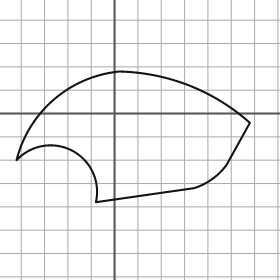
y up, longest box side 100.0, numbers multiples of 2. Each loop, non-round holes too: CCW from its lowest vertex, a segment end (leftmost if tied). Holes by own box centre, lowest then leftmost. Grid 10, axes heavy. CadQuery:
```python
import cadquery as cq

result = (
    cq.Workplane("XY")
    .moveTo(-8.0, -38.0)
    .lineTo(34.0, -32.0)
    .threePointArc((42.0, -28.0), (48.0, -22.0))
    .lineTo(58.0, -4.0)
    .threePointArc((32.0, 12.0), (2.0, 18.0))
    .threePointArc((-26.0, 6.0), (-42.0, -20.0))
    .threePointArc((-18.0, -16.0), (-8.0, -38.0))
    .close()
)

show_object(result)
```